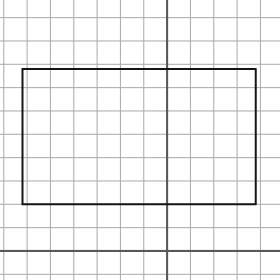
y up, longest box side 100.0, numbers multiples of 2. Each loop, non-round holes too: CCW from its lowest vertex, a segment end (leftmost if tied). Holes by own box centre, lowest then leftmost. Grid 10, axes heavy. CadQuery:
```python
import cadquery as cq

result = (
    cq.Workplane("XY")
    .moveTo(-62.0, 20.0)
    .lineTo(38.0, 20.0)
    .lineTo(38.0, 78.0)
    .lineTo(-62.0, 78.0)
    .close()
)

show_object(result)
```